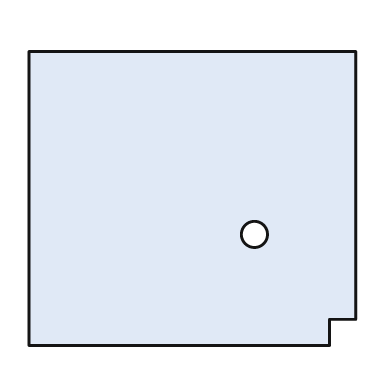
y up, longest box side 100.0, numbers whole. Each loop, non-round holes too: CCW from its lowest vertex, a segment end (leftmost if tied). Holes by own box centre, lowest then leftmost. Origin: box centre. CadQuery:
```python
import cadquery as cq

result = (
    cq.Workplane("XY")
    .moveTo(-50.0, -45.0)
    .lineTo(42.0, -45.0)
    .lineTo(42.0, -37.0)
    .lineTo(50.0, -37.0)
    .lineTo(50.0, 45.0)
    .lineTo(-50.0, 45.0)
    .close()
    .moveTo(19.0, -11.0)
    .circle(4.0)
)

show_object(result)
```